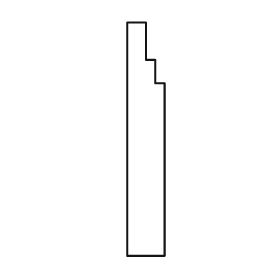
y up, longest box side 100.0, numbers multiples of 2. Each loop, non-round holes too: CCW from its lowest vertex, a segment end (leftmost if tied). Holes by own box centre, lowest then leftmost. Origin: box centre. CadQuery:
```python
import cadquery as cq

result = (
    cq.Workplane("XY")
    .moveTo(-8.0, -50.0)
    .lineTo(8.0, -50.0)
    .lineTo(8.0, 24.0)
    .lineTo(4.0, 24.0)
    .lineTo(4.0, 34.0)
    .lineTo(0.0, 34.0)
    .lineTo(0.0, 50.0)
    .lineTo(-8.0, 50.0)
    .close()
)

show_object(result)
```